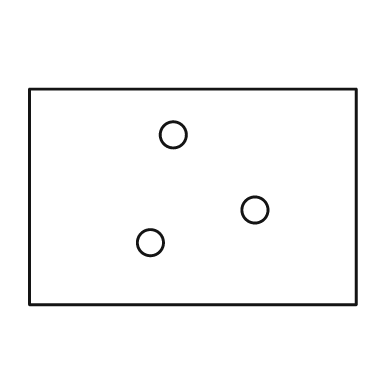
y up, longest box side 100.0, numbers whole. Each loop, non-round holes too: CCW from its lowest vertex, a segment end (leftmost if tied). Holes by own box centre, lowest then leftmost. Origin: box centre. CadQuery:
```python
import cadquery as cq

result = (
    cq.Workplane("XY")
    .moveTo(-50.0, -33.0)
    .lineTo(50.0, -33.0)
    .lineTo(50.0, 33.0)
    .lineTo(-50.0, 33.0)
    .close()
    .moveTo(-13.0, -14.0)
    .circle(4.0)
    .moveTo(19.0, -4.0)
    .circle(4.0)
    .moveTo(-6.0, 19.0)
    .circle(4.0)
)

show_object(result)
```